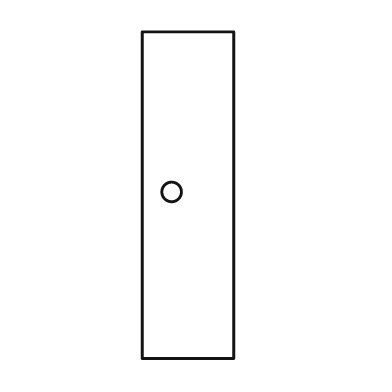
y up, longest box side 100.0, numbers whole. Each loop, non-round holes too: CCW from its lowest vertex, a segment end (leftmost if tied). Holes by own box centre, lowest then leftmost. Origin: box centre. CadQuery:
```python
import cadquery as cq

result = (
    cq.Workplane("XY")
    .moveTo(-14.0, -50.0)
    .lineTo(14.0, -50.0)
    .lineTo(14.0, 50.0)
    .lineTo(-14.0, 50.0)
    .close()
    .moveTo(-5.0, 1.0)
    .circle(3.0)
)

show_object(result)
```